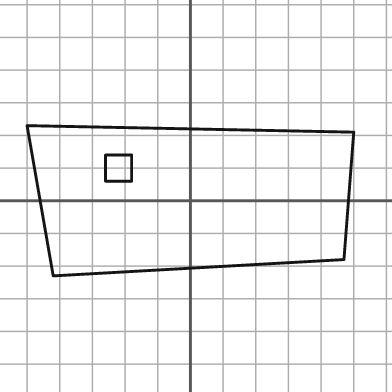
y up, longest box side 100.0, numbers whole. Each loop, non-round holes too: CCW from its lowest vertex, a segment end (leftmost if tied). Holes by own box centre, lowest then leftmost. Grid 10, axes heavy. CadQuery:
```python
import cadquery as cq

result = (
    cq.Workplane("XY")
    .moveTo(-42.0, -23.0)
    .lineTo(47.0, -18.0)
    .lineTo(50.0, 21.0)
    .lineTo(-50.0, 23.0)
    .close()
    .moveTo(-26.0, 6.0)
    .lineTo(-18.0, 6.0)
    .lineTo(-18.0, 14.0)
    .lineTo(-26.0, 14.0)
    .close()
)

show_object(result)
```